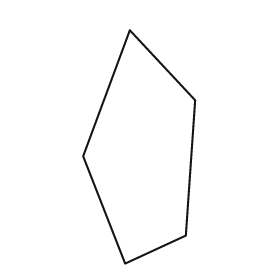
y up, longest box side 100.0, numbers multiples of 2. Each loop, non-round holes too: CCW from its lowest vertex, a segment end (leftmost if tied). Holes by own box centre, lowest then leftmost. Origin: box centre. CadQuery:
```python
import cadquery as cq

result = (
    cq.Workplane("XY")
    .moveTo(-6.0, -50.0)
    .lineTo(20.0, -38.0)
    .lineTo(24.0, 20.0)
    .lineTo(-4.0, 50.0)
    .lineTo(-24.0, -4.0)
    .close()
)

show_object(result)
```